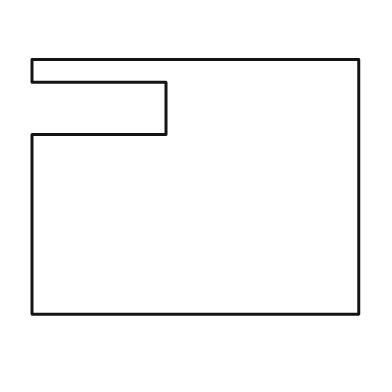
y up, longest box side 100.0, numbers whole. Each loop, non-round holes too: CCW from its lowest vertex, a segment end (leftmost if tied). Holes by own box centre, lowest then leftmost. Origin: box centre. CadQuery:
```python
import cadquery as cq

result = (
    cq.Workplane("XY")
    .moveTo(-50.0, -39.0)
    .lineTo(50.0, -39.0)
    .lineTo(50.0, 39.0)
    .lineTo(-50.0, 39.0)
    .lineTo(-50.0, 32.0)
    .lineTo(-9.0, 32.0)
    .lineTo(-9.0, 16.0)
    .lineTo(-50.0, 16.0)
    .close()
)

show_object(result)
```